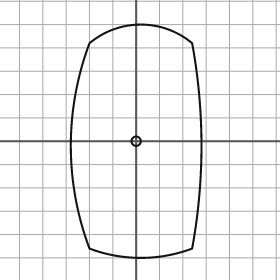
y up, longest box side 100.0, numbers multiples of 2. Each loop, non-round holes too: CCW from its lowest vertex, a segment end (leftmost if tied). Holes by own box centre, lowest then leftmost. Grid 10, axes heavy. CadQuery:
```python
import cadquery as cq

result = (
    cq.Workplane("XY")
    .moveTo(-20.0, -46.0)
    .threePointArc((2.0, -50.0), (24.0, -46.0))
    .threePointArc((28.0, -2.0), (24.0, 42.0))
    .threePointArc((2.0, 50.0), (-20.0, 42.0))
    .threePointArc((-28.0, -2.0), (-20.0, -46.0))
    .close()
    .moveTo(0.0, 0.0)
    .circle(2.0)
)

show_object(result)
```